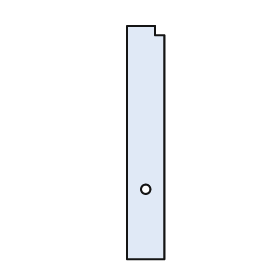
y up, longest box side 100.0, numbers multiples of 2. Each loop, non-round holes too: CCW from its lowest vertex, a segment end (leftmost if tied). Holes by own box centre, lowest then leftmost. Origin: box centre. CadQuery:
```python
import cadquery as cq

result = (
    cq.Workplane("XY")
    .moveTo(-8.0, -50.0)
    .lineTo(8.0, -50.0)
    .lineTo(8.0, 46.0)
    .lineTo(4.0, 46.0)
    .lineTo(4.0, 50.0)
    .lineTo(-8.0, 50.0)
    .close()
    .moveTo(0.0, -20.0)
    .circle(2.0)
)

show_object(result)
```